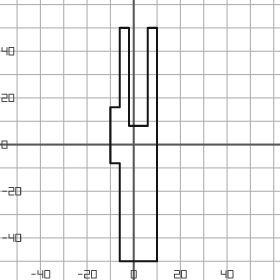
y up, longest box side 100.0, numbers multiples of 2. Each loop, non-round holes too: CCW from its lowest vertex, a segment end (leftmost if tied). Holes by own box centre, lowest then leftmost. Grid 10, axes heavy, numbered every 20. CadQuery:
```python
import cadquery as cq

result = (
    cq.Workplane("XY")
    .moveTo(-6.0, -50.0)
    .lineTo(10.0, -50.0)
    .lineTo(10.0, 50.0)
    .lineTo(6.0, 50.0)
    .lineTo(6.0, 8.0)
    .lineTo(-2.0, 8.0)
    .lineTo(-2.0, 50.0)
    .lineTo(-6.0, 50.0)
    .lineTo(-6.0, 16.0)
    .lineTo(-10.0, 16.0)
    .lineTo(-10.0, -8.0)
    .lineTo(-6.0, -8.0)
    .close()
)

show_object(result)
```